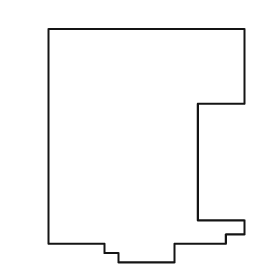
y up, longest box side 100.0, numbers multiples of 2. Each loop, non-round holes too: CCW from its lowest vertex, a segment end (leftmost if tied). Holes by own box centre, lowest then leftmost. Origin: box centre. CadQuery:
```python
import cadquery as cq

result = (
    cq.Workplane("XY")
    .moveTo(-12.0, -50.0)
    .lineTo(12.0, -50.0)
    .lineTo(12.0, -42.0)
    .lineTo(34.0, -42.0)
    .lineTo(34.0, -38.0)
    .lineTo(42.0, -38.0)
    .lineTo(42.0, -32.0)
    .lineTo(22.0, -32.0)
    .lineTo(22.0, 18.0)
    .lineTo(42.0, 18.0)
    .lineTo(42.0, 50.0)
    .lineTo(-42.0, 50.0)
    .lineTo(-42.0, -42.0)
    .lineTo(-18.0, -42.0)
    .lineTo(-18.0, -46.0)
    .lineTo(-12.0, -46.0)
    .close()
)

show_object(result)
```